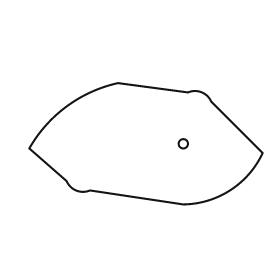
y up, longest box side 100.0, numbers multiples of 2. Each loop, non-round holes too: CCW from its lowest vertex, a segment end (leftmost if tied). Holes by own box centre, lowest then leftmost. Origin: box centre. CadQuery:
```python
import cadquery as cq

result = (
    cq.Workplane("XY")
    .moveTo(16.0, -26.0)
    .threePointArc((36.0, -20.0), (50.0, -4.0))
    .lineTo(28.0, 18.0)
    .threePointArc((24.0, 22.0), (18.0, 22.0))
    .lineTo(-12.0, 26.0)
    .threePointArc((-34.0, 16.0), (-50.0, -2.0))
    .lineTo(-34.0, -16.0)
    .threePointArc((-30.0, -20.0), (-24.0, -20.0))
    .close()
    .moveTo(16.0, 0.0)
    .circle(2.0)
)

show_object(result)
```